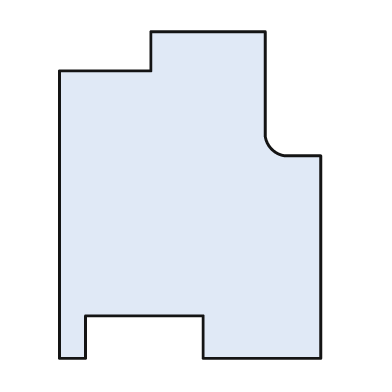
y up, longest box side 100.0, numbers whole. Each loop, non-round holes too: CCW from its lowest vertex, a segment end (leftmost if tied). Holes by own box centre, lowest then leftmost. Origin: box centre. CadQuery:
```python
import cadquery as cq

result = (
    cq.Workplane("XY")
    .moveTo(-40.0, -50.0)
    .lineTo(-32.0, -50.0)
    .lineTo(-32.0, -37.0)
    .lineTo(4.0, -37.0)
    .lineTo(4.0, -50.0)
    .lineTo(40.0, -50.0)
    .lineTo(40.0, 12.0)
    .lineTo(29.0, 12.0)
    .threePointArc((25.0, 14.0), (23.0, 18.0))
    .lineTo(23.0, 50.0)
    .lineTo(-12.0, 50.0)
    .lineTo(-12.0, 38.0)
    .lineTo(-40.0, 38.0)
    .close()
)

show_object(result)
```